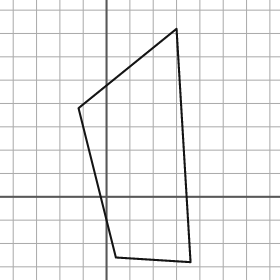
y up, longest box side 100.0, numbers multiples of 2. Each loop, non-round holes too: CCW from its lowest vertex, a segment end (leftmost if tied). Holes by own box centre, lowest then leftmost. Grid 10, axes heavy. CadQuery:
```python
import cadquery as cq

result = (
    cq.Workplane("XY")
    .moveTo(36.0, -28.0)
    .lineTo(30.0, 72.0)
    .lineTo(-12.0, 38.0)
    .lineTo(4.0, -26.0)
    .close()
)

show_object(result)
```